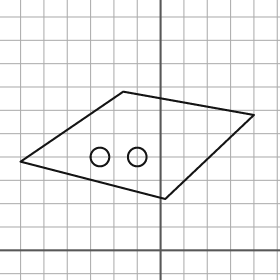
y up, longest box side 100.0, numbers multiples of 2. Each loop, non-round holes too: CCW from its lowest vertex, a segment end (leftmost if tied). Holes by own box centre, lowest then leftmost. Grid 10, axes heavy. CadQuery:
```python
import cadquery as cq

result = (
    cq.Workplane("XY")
    .moveTo(2.0, 22.0)
    .lineTo(40.0, 58.0)
    .lineTo(-16.0, 68.0)
    .lineTo(-60.0, 38.0)
    .close()
    .moveTo(-26.0, 40.0)
    .circle(4.0)
    .moveTo(-10.0, 40.0)
    .circle(4.0)
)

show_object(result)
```